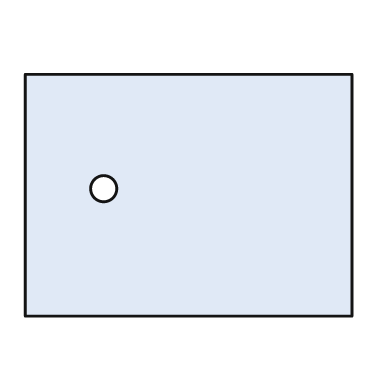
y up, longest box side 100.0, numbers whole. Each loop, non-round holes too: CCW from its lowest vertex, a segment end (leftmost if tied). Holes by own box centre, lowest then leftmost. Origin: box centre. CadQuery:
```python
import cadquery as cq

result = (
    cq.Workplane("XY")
    .moveTo(-50.0, -37.0)
    .lineTo(50.0, -37.0)
    .lineTo(50.0, 37.0)
    .lineTo(-50.0, 37.0)
    .close()
    .moveTo(-26.0, 2.0)
    .circle(4.0)
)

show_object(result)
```